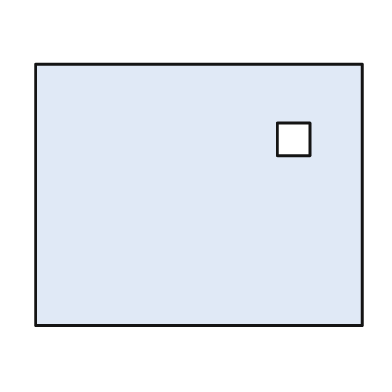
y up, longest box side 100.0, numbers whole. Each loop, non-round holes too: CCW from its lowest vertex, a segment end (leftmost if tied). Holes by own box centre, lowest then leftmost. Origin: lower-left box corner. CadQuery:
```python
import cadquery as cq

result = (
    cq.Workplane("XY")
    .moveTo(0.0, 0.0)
    .lineTo(100.0, 0.0)
    .lineTo(100.0, 80.0)
    .lineTo(0.0, 80.0)
    .close()
    .moveTo(74.0, 52.0)
    .lineTo(84.0, 52.0)
    .lineTo(84.0, 62.0)
    .lineTo(74.0, 62.0)
    .close()
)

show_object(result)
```